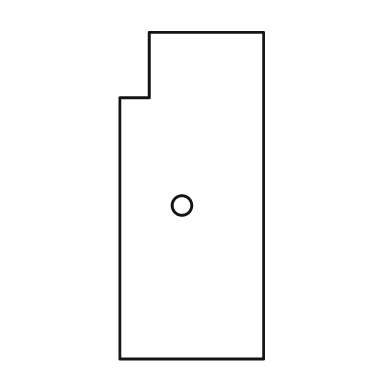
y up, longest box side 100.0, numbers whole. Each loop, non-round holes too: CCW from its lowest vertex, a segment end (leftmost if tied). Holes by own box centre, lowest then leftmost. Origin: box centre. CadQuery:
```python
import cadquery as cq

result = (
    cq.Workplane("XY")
    .moveTo(-22.0, -50.0)
    .lineTo(22.0, -50.0)
    .lineTo(22.0, 50.0)
    .lineTo(-13.0, 50.0)
    .lineTo(-13.0, 30.0)
    .lineTo(-22.0, 30.0)
    .close()
    .moveTo(-3.0, -3.0)
    .circle(3.0)
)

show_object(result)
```